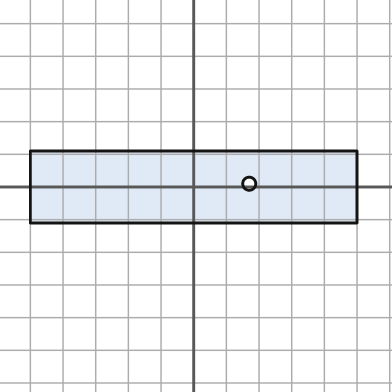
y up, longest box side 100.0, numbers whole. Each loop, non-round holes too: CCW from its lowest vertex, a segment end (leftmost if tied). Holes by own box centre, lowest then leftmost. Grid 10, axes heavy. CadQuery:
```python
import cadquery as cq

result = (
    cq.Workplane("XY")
    .moveTo(-50.0, -11.0)
    .lineTo(50.0, -11.0)
    .lineTo(50.0, 11.0)
    .lineTo(-50.0, 11.0)
    .close()
    .moveTo(17.0, 1.0)
    .circle(2.0)
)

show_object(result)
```